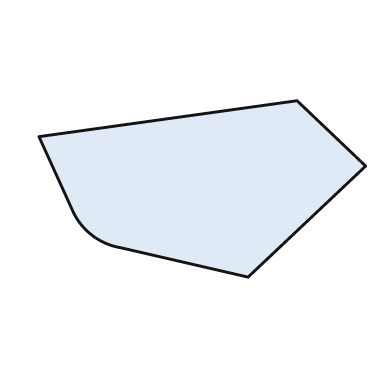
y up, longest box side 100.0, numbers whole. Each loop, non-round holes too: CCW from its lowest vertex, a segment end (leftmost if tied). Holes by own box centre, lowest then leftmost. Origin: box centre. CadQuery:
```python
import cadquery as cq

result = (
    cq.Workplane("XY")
    .moveTo(14.0, -27.0)
    .lineTo(50.0, 7.0)
    .lineTo(29.0, 27.0)
    .lineTo(-50.0, 16.0)
    .lineTo(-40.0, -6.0)
    .threePointArc((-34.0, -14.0), (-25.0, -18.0))
    .close()
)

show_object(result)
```